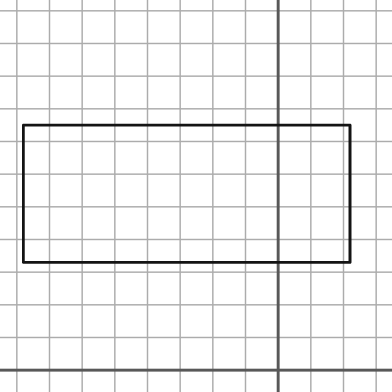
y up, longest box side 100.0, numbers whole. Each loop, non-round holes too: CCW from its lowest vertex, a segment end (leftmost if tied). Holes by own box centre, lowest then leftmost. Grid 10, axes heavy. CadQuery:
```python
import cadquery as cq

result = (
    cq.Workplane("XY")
    .moveTo(-78.0, 33.0)
    .lineTo(22.0, 33.0)
    .lineTo(22.0, 75.0)
    .lineTo(-78.0, 75.0)
    .close()
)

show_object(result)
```